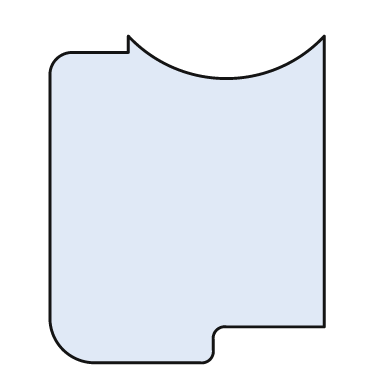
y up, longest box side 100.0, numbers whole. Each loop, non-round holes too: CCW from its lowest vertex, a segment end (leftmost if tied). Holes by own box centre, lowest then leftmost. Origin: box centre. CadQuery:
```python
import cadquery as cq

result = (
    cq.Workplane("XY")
    .moveTo(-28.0, -50.0)
    .lineTo(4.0, -50.0)
    .threePointArc((7.0, -49.0), (8.0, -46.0))
    .lineTo(8.0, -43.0)
    .threePointArc((9.0, -40.0), (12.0, -39.0))
    .lineTo(42.0, -39.0)
    .lineTo(42.0, 50.0)
    .threePointArc((12.0, 37.0), (-18.0, 50.0))
    .lineTo(-18.0, 45.0)
    .lineTo(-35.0, 45.0)
    .threePointArc((-40.0, 43.0), (-42.0, 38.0))
    .lineTo(-42.0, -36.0)
    .threePointArc((-38.0, -46.0), (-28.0, -50.0))
    .close()
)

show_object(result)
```